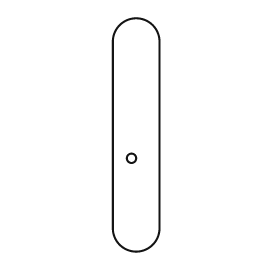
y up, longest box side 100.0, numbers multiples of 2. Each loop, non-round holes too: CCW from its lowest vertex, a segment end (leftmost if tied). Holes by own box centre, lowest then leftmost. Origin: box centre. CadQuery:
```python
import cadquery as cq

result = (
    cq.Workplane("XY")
    .moveTo(-10.0, -40.0)
    .threePointArc((0.0, -50.0), (10.0, -40.0))
    .lineTo(10.0, 40.0)
    .threePointArc((0.0, 50.0), (-10.0, 40.0))
    .close()
    .moveTo(-2.0, -10.0)
    .circle(2.0)
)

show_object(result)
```